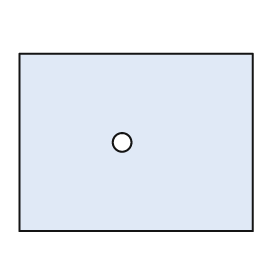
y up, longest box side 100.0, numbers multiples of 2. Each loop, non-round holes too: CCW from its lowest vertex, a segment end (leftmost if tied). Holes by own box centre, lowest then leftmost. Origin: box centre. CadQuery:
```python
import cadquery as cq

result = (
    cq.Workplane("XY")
    .moveTo(-50.0, -38.0)
    .lineTo(50.0, -38.0)
    .lineTo(50.0, 38.0)
    .lineTo(-50.0, 38.0)
    .close()
    .moveTo(-6.0, 0.0)
    .circle(4.0)
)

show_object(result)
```